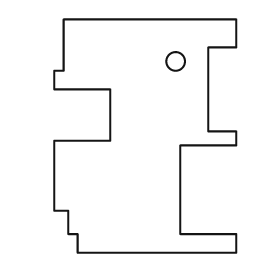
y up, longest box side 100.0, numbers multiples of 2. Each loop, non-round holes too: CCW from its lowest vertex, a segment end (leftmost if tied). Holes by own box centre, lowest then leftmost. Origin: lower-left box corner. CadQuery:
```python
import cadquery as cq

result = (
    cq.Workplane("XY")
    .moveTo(10.0, 0.0)
    .lineTo(78.0, 0.0)
    .lineTo(78.0, 8.0)
    .lineTo(54.0, 8.0)
    .lineTo(54.0, 46.0)
    .lineTo(78.0, 46.0)
    .lineTo(78.0, 52.0)
    .lineTo(66.0, 52.0)
    .lineTo(66.0, 88.0)
    .lineTo(78.0, 88.0)
    .lineTo(78.0, 100.0)
    .lineTo(4.0, 100.0)
    .lineTo(4.0, 78.0)
    .lineTo(0.0, 78.0)
    .lineTo(0.0, 70.0)
    .lineTo(24.0, 70.0)
    .lineTo(24.0, 48.0)
    .lineTo(0.0, 48.0)
    .lineTo(0.0, 18.0)
    .lineTo(6.0, 18.0)
    .lineTo(6.0, 8.0)
    .lineTo(10.0, 8.0)
    .close()
    .moveTo(52.0, 82.0)
    .circle(4.0)
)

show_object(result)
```